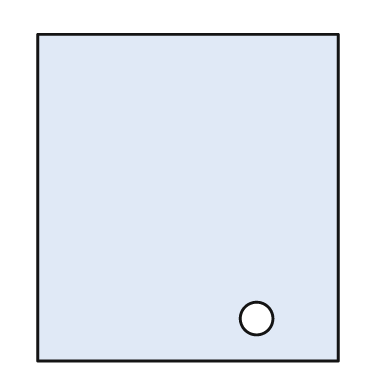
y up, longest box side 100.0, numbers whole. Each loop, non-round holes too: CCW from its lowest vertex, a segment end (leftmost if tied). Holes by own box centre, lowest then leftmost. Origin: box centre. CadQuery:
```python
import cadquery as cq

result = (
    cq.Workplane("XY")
    .moveTo(-46.0, -50.0)
    .lineTo(46.0, -50.0)
    .lineTo(46.0, 50.0)
    .lineTo(-46.0, 50.0)
    .close()
    .moveTo(21.0, -37.0)
    .circle(5.0)
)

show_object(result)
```